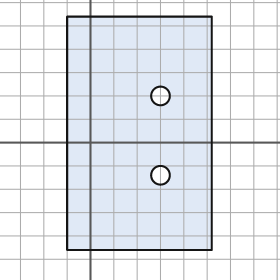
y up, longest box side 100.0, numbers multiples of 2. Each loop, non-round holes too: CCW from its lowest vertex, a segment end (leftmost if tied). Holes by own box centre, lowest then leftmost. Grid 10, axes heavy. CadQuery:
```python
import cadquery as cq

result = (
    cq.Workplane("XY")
    .moveTo(-10.0, -46.0)
    .lineTo(52.0, -46.0)
    .lineTo(52.0, 54.0)
    .lineTo(-10.0, 54.0)
    .close()
    .moveTo(30.0, -14.0)
    .circle(4.0)
    .moveTo(30.0, 20.0)
    .circle(4.0)
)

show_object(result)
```